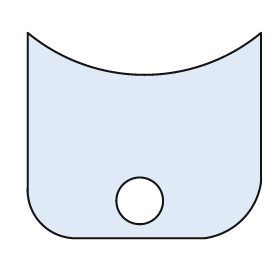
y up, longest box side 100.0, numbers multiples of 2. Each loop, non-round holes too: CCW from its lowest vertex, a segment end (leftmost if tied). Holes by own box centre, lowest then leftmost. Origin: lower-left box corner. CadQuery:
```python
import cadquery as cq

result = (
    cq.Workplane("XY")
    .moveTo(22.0, 0.0)
    .lineTo(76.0, 0.0)
    .threePointArc((92.0, 8.0), (100.0, 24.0))
    .lineTo(100.0, 88.0)
    .threePointArc((50.0, 70.0), (0.0, 88.0))
    .lineTo(0.0, 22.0)
    .threePointArc((6.0, 6.0), (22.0, 0.0))
    .close()
    .moveTo(48.0, 16.0)
    .circle(10.0)
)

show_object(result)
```